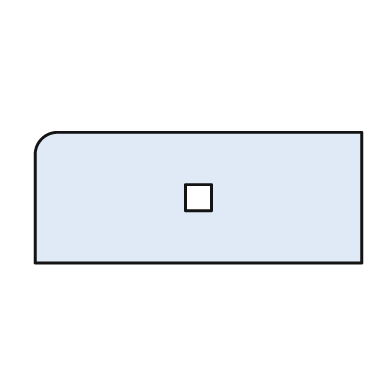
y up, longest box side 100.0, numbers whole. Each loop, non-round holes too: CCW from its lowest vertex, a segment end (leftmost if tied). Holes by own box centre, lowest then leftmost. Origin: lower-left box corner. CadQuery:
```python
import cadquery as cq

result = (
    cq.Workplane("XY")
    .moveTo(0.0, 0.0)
    .lineTo(100.0, 0.0)
    .lineTo(100.0, 40.0)
    .lineTo(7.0, 40.0)
    .threePointArc((2.0, 38.0), (0.0, 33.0))
    .close()
    .moveTo(46.0, 16.0)
    .lineTo(54.0, 16.0)
    .lineTo(54.0, 24.0)
    .lineTo(46.0, 24.0)
    .close()
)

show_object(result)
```